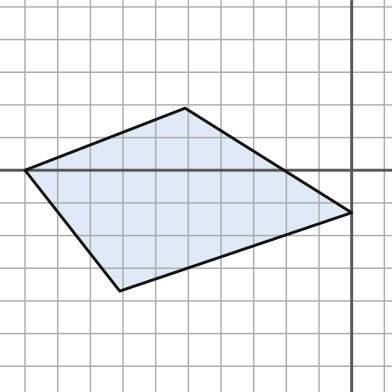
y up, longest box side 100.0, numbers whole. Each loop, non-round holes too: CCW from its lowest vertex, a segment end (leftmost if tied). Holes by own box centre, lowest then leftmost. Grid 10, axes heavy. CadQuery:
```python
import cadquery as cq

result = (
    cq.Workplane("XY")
    .moveTo(-71.0, -37.0)
    .lineTo(0.0, -13.0)
    .lineTo(-51.0, 19.0)
    .lineTo(-100.0, 0.0)
    .close()
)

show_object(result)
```